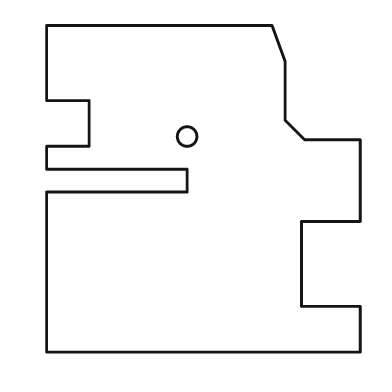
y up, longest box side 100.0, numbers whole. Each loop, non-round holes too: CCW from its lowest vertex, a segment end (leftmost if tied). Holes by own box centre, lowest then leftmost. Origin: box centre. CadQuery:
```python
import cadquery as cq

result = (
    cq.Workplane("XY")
    .moveTo(-48.0, -50.0)
    .lineTo(48.0, -50.0)
    .lineTo(48.0, -36.0)
    .lineTo(30.0, -36.0)
    .lineTo(30.0, -10.0)
    .lineTo(48.0, -10.0)
    .lineTo(48.0, 15.0)
    .lineTo(31.0, 15.0)
    .lineTo(25.0, 21.0)
    .lineTo(25.0, 39.0)
    .lineTo(21.0, 50.0)
    .lineTo(-48.0, 50.0)
    .lineTo(-48.0, 27.0)
    .lineTo(-35.0, 27.0)
    .lineTo(-35.0, 13.0)
    .lineTo(-48.0, 13.0)
    .lineTo(-48.0, 6.0)
    .lineTo(-5.0, 6.0)
    .lineTo(-5.0, -1.0)
    .lineTo(-48.0, -1.0)
    .close()
    .moveTo(-5.0, 16.0)
    .circle(3.0)
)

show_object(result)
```